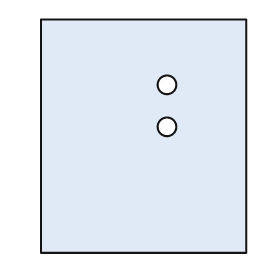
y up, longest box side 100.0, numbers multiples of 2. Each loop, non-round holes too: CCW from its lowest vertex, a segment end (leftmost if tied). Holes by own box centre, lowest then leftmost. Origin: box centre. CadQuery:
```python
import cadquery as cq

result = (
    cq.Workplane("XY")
    .moveTo(-44.0, -50.0)
    .lineTo(44.0, -50.0)
    .lineTo(44.0, 50.0)
    .lineTo(-44.0, 50.0)
    .close()
    .moveTo(10.0, 4.0)
    .circle(4.0)
    .moveTo(10.0, 22.0)
    .circle(4.0)
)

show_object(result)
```